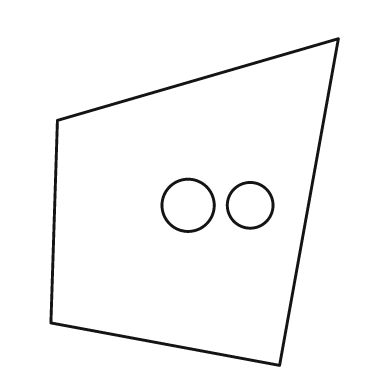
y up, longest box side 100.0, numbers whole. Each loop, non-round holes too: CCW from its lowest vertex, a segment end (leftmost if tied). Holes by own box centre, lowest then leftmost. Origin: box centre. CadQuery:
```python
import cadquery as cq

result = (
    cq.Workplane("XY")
    .moveTo(26.0, -50.0)
    .lineTo(44.0, 50.0)
    .lineTo(-42.0, 25.0)
    .lineTo(-44.0, -37.0)
    .close()
    .moveTo(-2.0, -1.0)
    .circle(8.0)
    .moveTo(17.0, -1.0)
    .circle(7.0)
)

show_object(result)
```